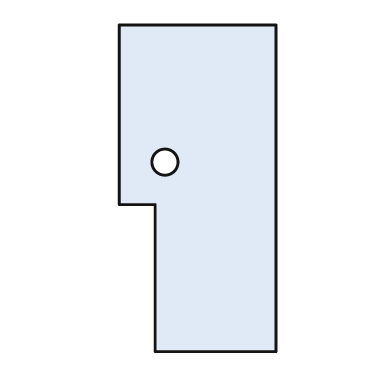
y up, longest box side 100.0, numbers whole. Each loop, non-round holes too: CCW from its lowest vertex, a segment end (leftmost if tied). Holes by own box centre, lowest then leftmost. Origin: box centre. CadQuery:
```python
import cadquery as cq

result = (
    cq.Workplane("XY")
    .moveTo(-13.0, -50.0)
    .lineTo(24.0, -50.0)
    .lineTo(24.0, 50.0)
    .lineTo(-24.0, 50.0)
    .lineTo(-24.0, -5.0)
    .lineTo(-13.0, -5.0)
    .close()
    .moveTo(-10.0, 8.0)
    .circle(4.0)
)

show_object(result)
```